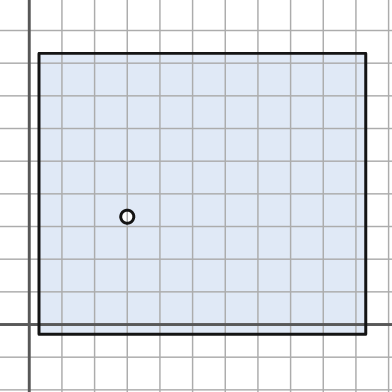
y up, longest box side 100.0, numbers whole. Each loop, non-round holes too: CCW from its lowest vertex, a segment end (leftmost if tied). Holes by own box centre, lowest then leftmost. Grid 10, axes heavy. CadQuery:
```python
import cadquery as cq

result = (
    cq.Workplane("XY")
    .moveTo(3.0, -3.0)
    .lineTo(103.0, -3.0)
    .lineTo(103.0, 83.0)
    .lineTo(3.0, 83.0)
    .close()
    .moveTo(30.0, 33.0)
    .circle(2.0)
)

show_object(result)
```